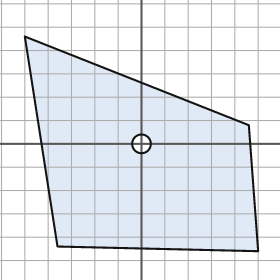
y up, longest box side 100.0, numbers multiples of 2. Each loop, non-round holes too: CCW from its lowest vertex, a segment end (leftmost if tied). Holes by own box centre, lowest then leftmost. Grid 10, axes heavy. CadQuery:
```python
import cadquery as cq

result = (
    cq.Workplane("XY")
    .moveTo(50.0, -46.0)
    .lineTo(46.0, 8.0)
    .lineTo(-50.0, 46.0)
    .lineTo(-36.0, -44.0)
    .close()
    .moveTo(0.0, 0.0)
    .circle(4.0)
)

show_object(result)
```